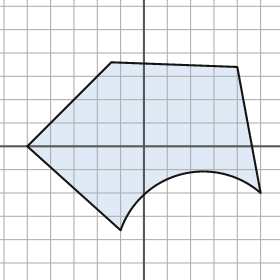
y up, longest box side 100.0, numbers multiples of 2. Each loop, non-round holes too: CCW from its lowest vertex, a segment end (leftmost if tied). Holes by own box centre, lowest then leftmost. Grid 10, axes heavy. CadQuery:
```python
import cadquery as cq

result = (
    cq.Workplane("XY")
    .moveTo(-10.0, -36.0)
    .threePointArc((16.0, -12.0), (50.0, -20.0))
    .lineTo(40.0, 34.0)
    .lineTo(-14.0, 36.0)
    .lineTo(-50.0, 0.0)
    .close()
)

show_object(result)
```